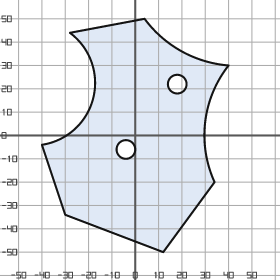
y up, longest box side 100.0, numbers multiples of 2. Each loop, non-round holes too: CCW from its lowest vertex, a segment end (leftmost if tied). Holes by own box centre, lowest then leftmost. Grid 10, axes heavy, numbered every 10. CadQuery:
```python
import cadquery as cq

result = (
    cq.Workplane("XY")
    .moveTo(12.0, -50.0)
    .lineTo(34.0, -20.0)
    .threePointArc((30.0, 6.0), (40.0, 30.0))
    .threePointArc((20.0, 36.0), (4.0, 50.0))
    .lineTo(-28.0, 44.0)
    .threePointArc((-18.0, 16.0), (-40.0, -4.0))
    .lineTo(-30.0, -34.0)
    .close()
    .moveTo(-4.0, -6.0)
    .circle(4.0)
    .moveTo(18.0, 22.0)
    .circle(4.0)
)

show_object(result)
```